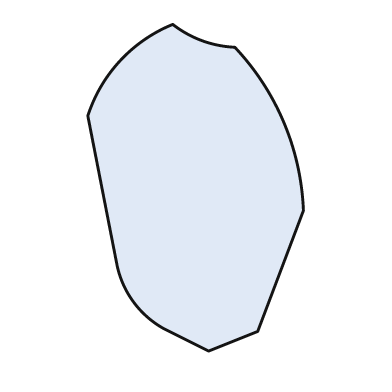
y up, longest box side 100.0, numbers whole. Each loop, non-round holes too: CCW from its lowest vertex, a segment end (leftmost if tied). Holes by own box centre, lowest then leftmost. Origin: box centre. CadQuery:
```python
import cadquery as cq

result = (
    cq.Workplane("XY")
    .moveTo(4.0, -50.0)
    .lineTo(19.0, -44.0)
    .lineTo(33.0, -7.0)
    .threePointArc((27.0, 20.0), (12.0, 43.0))
    .threePointArc((2.0, 45.0), (-7.0, 50.0))
    .threePointArc((-23.0, 39.0), (-33.0, 22.0))
    .lineTo(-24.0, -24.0)
    .threePointArc((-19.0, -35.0), (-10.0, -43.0))
    .close()
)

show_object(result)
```